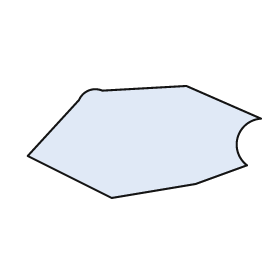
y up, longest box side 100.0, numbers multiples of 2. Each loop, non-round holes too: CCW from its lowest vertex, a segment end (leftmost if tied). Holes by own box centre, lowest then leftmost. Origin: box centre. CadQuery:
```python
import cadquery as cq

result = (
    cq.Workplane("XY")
    .moveTo(-14.0, -24.0)
    .lineTo(22.0, -18.0)
    .lineTo(44.0, -10.0)
    .threePointArc((40.0, 2.0), (50.0, 10.0))
    .lineTo(18.0, 24.0)
    .lineTo(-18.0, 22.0)
    .threePointArc((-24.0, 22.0), (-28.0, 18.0))
    .lineTo(-50.0, -6.0)
    .close()
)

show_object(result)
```